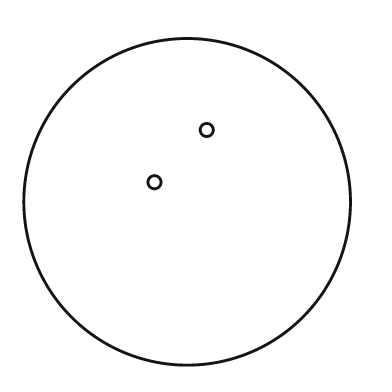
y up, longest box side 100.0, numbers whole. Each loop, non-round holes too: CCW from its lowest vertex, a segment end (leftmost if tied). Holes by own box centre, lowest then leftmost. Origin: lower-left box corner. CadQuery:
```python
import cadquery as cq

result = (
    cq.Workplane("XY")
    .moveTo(50.0, 50.0)
    .circle(50.0)
    .moveTo(40.0, 56.0)
    .circle(2.0)
    .moveTo(56.0, 72.0)
    .circle(2.0)
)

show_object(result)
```